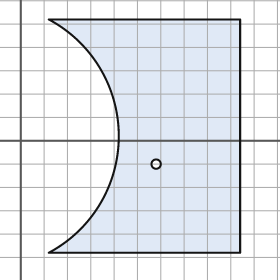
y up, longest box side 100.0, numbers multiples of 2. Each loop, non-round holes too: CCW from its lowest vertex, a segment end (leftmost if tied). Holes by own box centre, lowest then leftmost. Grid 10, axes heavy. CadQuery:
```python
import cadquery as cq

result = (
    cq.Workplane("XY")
    .moveTo(12.0, -48.0)
    .lineTo(94.0, -48.0)
    .lineTo(94.0, 52.0)
    .lineTo(12.0, 52.0)
    .threePointArc((42.0, 2.0), (12.0, -48.0))
    .close()
    .moveTo(58.0, -10.0)
    .circle(2.0)
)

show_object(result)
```